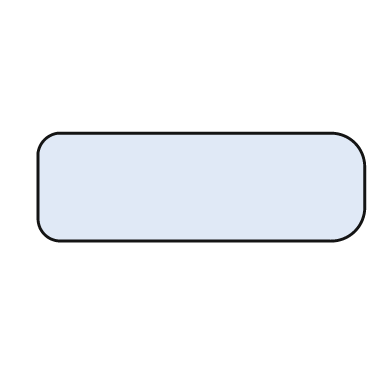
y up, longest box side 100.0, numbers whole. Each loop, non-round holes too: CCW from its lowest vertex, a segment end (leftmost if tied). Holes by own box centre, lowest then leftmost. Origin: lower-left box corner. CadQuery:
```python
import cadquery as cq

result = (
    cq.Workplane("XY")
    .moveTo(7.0, 0.0)
    .lineTo(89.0, 0.0)
    .threePointArc((97.0, 3.0), (100.0, 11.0))
    .lineTo(100.0, 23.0)
    .threePointArc((97.0, 30.0), (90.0, 33.0))
    .lineTo(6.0, 33.0)
    .threePointArc((2.0, 31.0), (0.0, 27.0))
    .lineTo(0.0, 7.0)
    .threePointArc((2.0, 2.0), (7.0, 0.0))
    .close()
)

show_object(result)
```